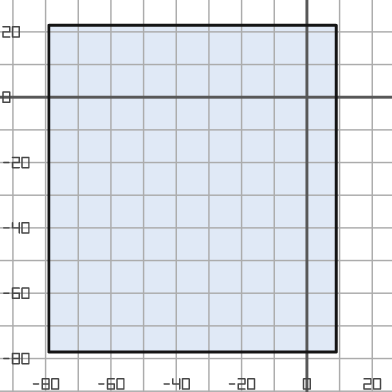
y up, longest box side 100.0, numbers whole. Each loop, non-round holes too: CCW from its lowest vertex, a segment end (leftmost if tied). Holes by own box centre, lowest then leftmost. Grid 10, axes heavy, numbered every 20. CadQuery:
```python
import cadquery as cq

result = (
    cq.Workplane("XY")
    .moveTo(-79.0, -78.0)
    .lineTo(9.0, -78.0)
    .lineTo(9.0, 22.0)
    .lineTo(-79.0, 22.0)
    .close()
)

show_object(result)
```